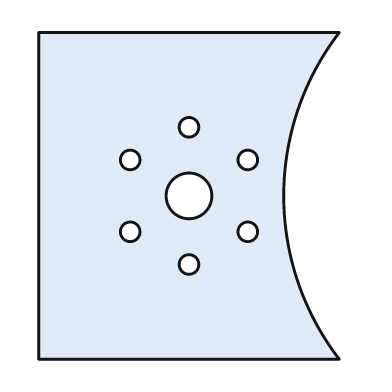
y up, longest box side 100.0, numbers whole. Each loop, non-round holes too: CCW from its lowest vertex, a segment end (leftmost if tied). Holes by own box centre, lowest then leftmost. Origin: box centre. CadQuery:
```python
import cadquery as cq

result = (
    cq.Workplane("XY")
    .moveTo(-46.0, -50.0)
    .lineTo(46.0, -50.0)
    .threePointArc((29.0, 0.0), (46.0, 50.0))
    .lineTo(-46.0, 50.0)
    .close()
    .moveTo(0.0, -21.0)
    .circle(3.0)
    .moveTo(-18.0, -11.0)
    .circle(3.0)
    .moveTo(18.0, -11.0)
    .circle(3.0)
    .moveTo(0.0, 0.0)
    .circle(7.0)
    .moveTo(-18.0, 11.0)
    .circle(3.0)
    .moveTo(18.0, 11.0)
    .circle(3.0)
    .moveTo(0.0, 21.0)
    .circle(3.0)
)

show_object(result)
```